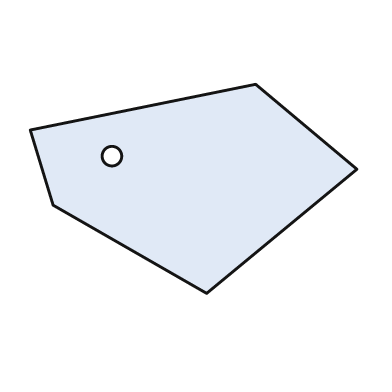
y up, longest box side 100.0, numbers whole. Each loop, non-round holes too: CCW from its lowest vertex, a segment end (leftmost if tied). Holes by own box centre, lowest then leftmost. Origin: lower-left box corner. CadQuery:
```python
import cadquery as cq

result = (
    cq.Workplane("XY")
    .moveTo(54.0, 0.0)
    .lineTo(100.0, 38.0)
    .lineTo(69.0, 64.0)
    .lineTo(0.0, 50.0)
    .lineTo(7.0, 27.0)
    .close()
    .moveTo(25.0, 42.0)
    .circle(3.0)
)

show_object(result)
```